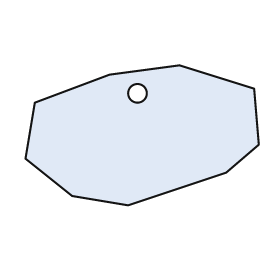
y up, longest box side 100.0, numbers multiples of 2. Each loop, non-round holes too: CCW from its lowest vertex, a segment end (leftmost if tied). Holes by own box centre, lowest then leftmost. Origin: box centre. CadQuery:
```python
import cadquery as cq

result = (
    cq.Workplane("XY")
    .moveTo(-6.0, -30.0)
    .lineTo(36.0, -16.0)
    .lineTo(50.0, -4.0)
    .lineTo(48.0, 20.0)
    .lineTo(16.0, 30.0)
    .lineTo(-14.0, 26.0)
    .lineTo(-46.0, 14.0)
    .lineTo(-50.0, -10.0)
    .lineTo(-30.0, -26.0)
    .close()
    .moveTo(-2.0, 18.0)
    .circle(4.0)
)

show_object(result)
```